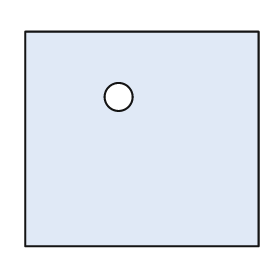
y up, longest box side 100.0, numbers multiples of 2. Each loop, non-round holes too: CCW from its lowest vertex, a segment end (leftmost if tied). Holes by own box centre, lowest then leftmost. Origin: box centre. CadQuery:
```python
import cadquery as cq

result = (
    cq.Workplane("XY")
    .moveTo(-50.0, -46.0)
    .lineTo(50.0, -46.0)
    .lineTo(50.0, 46.0)
    .lineTo(-50.0, 46.0)
    .close()
    .moveTo(-10.0, 18.0)
    .circle(6.0)
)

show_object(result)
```